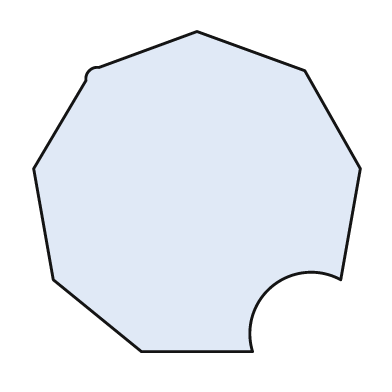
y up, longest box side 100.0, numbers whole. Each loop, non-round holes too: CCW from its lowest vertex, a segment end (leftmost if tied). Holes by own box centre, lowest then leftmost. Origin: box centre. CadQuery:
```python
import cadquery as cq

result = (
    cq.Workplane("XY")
    .moveTo(-17.0, -49.0)
    .lineTo(17.0, -49.0)
    .threePointArc((23.0, -29.0), (44.0, -27.0))
    .lineTo(50.0, 7.0)
    .lineTo(33.0, 37.0)
    .lineTo(0.0, 49.0)
    .lineTo(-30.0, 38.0)
    .threePointArc((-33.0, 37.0), (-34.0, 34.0))
    .lineTo(-50.0, 7.0)
    .lineTo(-44.0, -27.0)
    .close()
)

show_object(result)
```